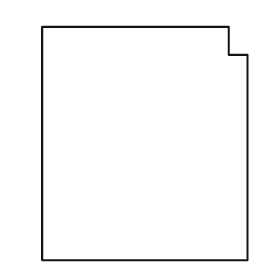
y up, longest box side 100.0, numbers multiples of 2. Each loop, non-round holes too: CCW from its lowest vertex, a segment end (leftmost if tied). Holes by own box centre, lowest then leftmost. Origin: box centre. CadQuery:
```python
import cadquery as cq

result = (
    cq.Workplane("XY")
    .moveTo(-44.0, -50.0)
    .lineTo(44.0, -50.0)
    .lineTo(44.0, 38.0)
    .lineTo(36.0, 38.0)
    .lineTo(36.0, 50.0)
    .lineTo(-44.0, 50.0)
    .close()
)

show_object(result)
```